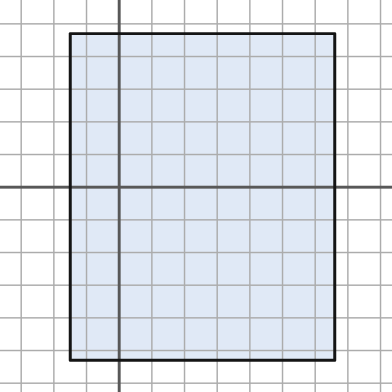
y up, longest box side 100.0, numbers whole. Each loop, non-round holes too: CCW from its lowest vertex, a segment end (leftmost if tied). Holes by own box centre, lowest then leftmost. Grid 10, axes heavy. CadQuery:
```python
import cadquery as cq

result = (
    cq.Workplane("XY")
    .moveTo(-15.0, -53.0)
    .lineTo(66.0, -53.0)
    .lineTo(66.0, 47.0)
    .lineTo(-15.0, 47.0)
    .close()
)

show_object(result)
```